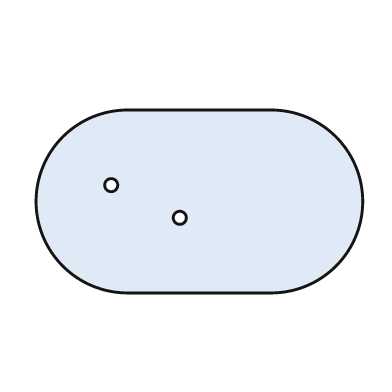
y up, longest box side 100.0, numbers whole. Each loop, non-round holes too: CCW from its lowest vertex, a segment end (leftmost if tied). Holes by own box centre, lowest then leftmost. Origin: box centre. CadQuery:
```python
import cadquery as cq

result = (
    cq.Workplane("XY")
    .moveTo(-22.0, -28.0)
    .lineTo(22.0, -28.0)
    .threePointArc((50.0, 0.0), (22.0, 28.0))
    .lineTo(-22.0, 28.0)
    .threePointArc((-50.0, 0.0), (-22.0, -28.0))
    .close()
    .moveTo(-6.0, -5.0)
    .circle(2.0)
    .moveTo(-27.0, 5.0)
    .circle(2.0)
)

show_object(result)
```